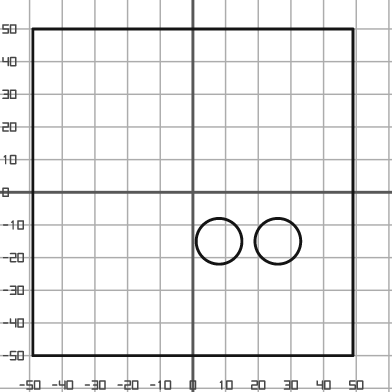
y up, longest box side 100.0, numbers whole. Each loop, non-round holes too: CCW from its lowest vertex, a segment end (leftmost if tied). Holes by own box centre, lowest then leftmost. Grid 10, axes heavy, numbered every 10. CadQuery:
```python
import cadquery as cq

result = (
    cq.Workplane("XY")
    .moveTo(-49.0, -50.0)
    .lineTo(49.0, -50.0)
    .lineTo(49.0, 50.0)
    .lineTo(-49.0, 50.0)
    .close()
    .moveTo(8.0, -15.0)
    .circle(7.0)
    .moveTo(26.0, -15.0)
    .circle(7.0)
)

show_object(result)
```